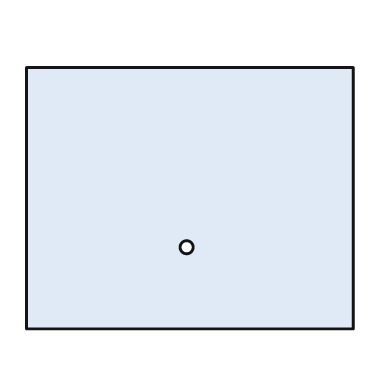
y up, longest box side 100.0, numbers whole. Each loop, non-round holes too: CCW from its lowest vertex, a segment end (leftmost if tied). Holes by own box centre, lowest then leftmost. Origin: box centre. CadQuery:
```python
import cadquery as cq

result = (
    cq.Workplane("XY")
    .moveTo(-50.0, -40.0)
    .lineTo(50.0, -40.0)
    .lineTo(50.0, 40.0)
    .lineTo(-50.0, 40.0)
    .close()
    .moveTo(-1.0, -15.0)
    .circle(2.0)
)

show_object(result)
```